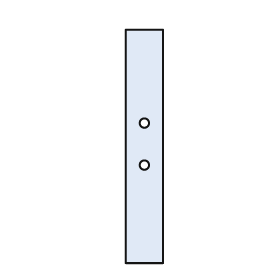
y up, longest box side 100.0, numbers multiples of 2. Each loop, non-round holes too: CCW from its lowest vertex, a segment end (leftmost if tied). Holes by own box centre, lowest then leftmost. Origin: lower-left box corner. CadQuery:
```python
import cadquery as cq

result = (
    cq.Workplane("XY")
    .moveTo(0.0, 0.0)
    .lineTo(16.0, 0.0)
    .lineTo(16.0, 100.0)
    .lineTo(0.0, 100.0)
    .close()
    .moveTo(8.0, 42.0)
    .circle(2.0)
    .moveTo(8.0, 60.0)
    .circle(2.0)
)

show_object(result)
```